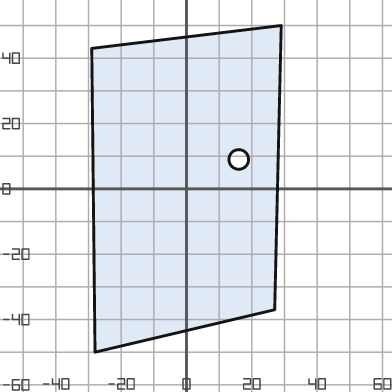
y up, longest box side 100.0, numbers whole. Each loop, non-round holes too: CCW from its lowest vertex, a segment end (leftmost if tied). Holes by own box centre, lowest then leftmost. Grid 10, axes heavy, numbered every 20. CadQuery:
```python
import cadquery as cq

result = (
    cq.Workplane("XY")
    .moveTo(-28.0, -50.0)
    .lineTo(27.0, -37.0)
    .lineTo(29.0, 50.0)
    .lineTo(-29.0, 43.0)
    .close()
    .moveTo(16.0, 9.0)
    .circle(3.0)
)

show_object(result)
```